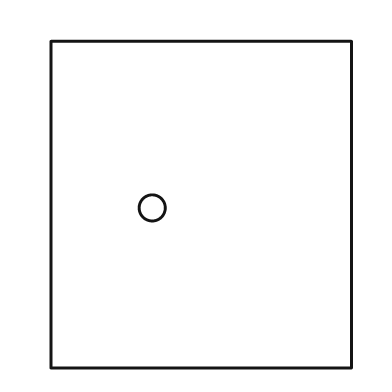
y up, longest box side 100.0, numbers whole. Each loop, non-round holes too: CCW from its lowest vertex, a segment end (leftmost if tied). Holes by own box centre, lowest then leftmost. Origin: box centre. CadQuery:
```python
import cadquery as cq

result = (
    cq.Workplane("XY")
    .moveTo(-46.0, -50.0)
    .lineTo(46.0, -50.0)
    .lineTo(46.0, 50.0)
    .lineTo(-46.0, 50.0)
    .close()
    .moveTo(-15.0, -1.0)
    .circle(4.0)
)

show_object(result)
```